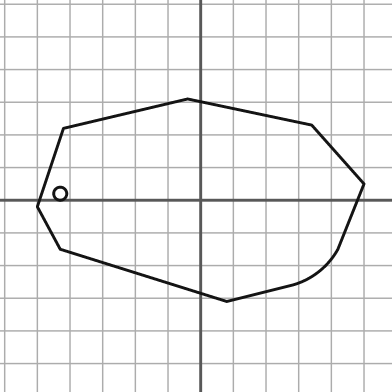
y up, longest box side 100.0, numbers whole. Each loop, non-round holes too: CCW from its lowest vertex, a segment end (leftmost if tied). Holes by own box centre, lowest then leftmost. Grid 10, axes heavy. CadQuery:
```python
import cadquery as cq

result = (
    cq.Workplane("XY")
    .moveTo(8.0, -31.0)
    .lineTo(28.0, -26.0)
    .threePointArc((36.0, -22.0), (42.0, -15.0))
    .lineTo(50.0, 5.0)
    .lineTo(34.0, 23.0)
    .lineTo(-4.0, 31.0)
    .lineTo(-42.0, 22.0)
    .lineTo(-50.0, -2.0)
    .lineTo(-43.0, -15.0)
    .close()
    .moveTo(-43.0, 2.0)
    .circle(2.0)
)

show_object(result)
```